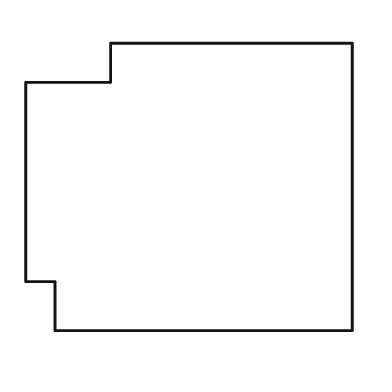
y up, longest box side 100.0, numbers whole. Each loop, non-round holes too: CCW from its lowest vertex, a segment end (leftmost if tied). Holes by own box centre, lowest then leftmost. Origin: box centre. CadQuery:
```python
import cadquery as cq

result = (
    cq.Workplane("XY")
    .moveTo(-41.0, -44.0)
    .lineTo(50.0, -44.0)
    .lineTo(50.0, 44.0)
    .lineTo(-24.0, 44.0)
    .lineTo(-24.0, 32.0)
    .lineTo(-50.0, 32.0)
    .lineTo(-50.0, -29.0)
    .lineTo(-41.0, -29.0)
    .close()
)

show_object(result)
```